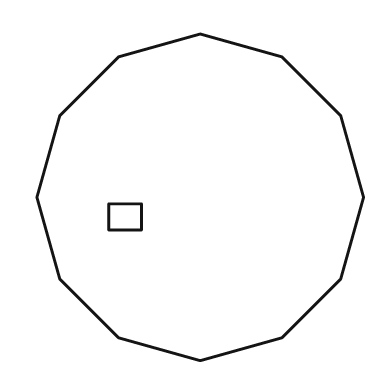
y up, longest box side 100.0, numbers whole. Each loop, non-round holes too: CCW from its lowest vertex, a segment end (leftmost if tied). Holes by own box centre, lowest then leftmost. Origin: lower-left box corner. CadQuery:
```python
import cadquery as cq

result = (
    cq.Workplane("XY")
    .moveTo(50.0, 0.0)
    .lineTo(75.0, 7.0)
    .lineTo(93.0, 25.0)
    .lineTo(100.0, 50.0)
    .lineTo(93.0, 75.0)
    .lineTo(75.0, 93.0)
    .lineTo(50.0, 100.0)
    .lineTo(25.0, 93.0)
    .lineTo(7.0, 75.0)
    .lineTo(0.0, 50.0)
    .lineTo(7.0, 25.0)
    .lineTo(25.0, 7.0)
    .close()
    .moveTo(22.0, 40.0)
    .lineTo(32.0, 40.0)
    .lineTo(32.0, 48.0)
    .lineTo(22.0, 48.0)
    .close()
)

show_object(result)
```